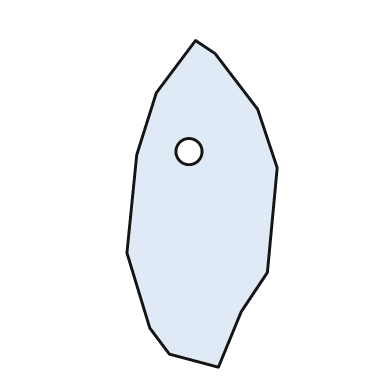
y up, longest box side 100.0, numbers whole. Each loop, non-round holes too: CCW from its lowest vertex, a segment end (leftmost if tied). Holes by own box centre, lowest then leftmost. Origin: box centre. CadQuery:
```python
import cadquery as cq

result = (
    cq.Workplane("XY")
    .moveTo(5.0, -50.0)
    .lineTo(12.0, -33.0)
    .lineTo(20.0, -21.0)
    .lineTo(23.0, 11.0)
    .lineTo(17.0, 29.0)
    .lineTo(4.0, 46.0)
    .lineTo(-2.0, 50.0)
    .lineTo(-14.0, 34.0)
    .lineTo(-20.0, 15.0)
    .lineTo(-23.0, -15.0)
    .lineTo(-16.0, -38.0)
    .lineTo(-10.0, -46.0)
    .close()
    .moveTo(-4.0, 16.0)
    .circle(4.0)
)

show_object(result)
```